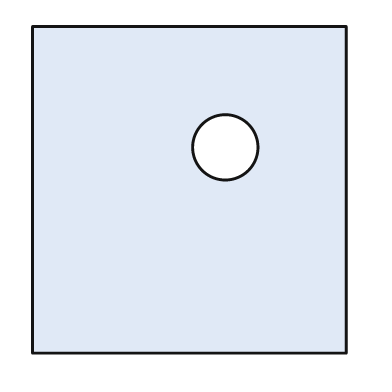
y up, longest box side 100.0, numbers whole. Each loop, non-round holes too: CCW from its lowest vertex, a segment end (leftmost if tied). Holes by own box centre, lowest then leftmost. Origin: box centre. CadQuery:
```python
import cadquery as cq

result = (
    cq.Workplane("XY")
    .moveTo(-48.0, -50.0)
    .lineTo(48.0, -50.0)
    .lineTo(48.0, 50.0)
    .lineTo(-48.0, 50.0)
    .close()
    .moveTo(11.0, 13.0)
    .circle(10.0)
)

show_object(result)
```